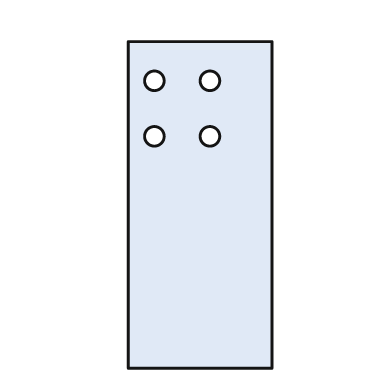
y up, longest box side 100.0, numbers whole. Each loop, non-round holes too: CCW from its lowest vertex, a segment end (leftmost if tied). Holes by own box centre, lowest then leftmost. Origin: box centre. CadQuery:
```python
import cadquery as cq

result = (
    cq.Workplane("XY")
    .moveTo(-22.0, -50.0)
    .lineTo(22.0, -50.0)
    .lineTo(22.0, 50.0)
    .lineTo(-22.0, 50.0)
    .close()
    .moveTo(-14.0, 21.0)
    .circle(3.0)
    .moveTo(3.0, 21.0)
    .circle(3.0)
    .moveTo(-14.0, 38.0)
    .circle(3.0)
    .moveTo(3.0, 38.0)
    .circle(3.0)
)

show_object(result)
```